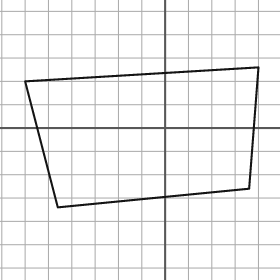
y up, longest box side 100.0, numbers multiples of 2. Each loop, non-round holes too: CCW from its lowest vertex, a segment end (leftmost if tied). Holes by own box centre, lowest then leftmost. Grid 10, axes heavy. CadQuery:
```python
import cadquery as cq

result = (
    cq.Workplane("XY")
    .moveTo(-46.0, -34.0)
    .lineTo(36.0, -26.0)
    .lineTo(40.0, 26.0)
    .lineTo(-60.0, 20.0)
    .close()
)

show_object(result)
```